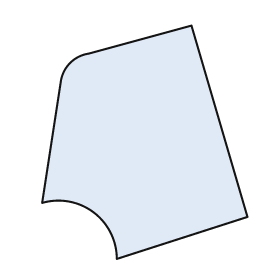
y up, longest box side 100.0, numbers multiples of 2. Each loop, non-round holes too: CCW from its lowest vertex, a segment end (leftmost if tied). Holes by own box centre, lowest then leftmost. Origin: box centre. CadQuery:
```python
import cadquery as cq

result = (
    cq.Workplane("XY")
    .moveTo(-12.0, -50.0)
    .lineTo(44.0, -32.0)
    .lineTo(20.0, 50.0)
    .lineTo(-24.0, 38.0)
    .threePointArc((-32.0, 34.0), (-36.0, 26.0))
    .lineTo(-44.0, -26.0)
    .threePointArc((-22.0, -30.0), (-12.0, -50.0))
    .close()
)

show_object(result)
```